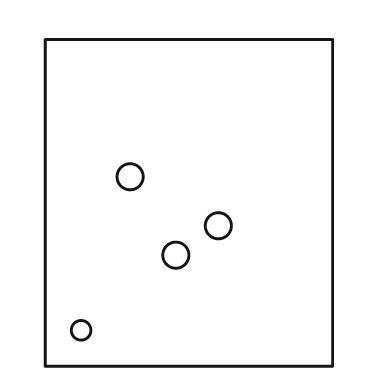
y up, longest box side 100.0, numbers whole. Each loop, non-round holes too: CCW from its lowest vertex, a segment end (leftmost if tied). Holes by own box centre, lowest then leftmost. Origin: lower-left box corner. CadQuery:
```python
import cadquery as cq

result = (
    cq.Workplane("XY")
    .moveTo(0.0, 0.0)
    .lineTo(88.0, 0.0)
    .lineTo(88.0, 100.0)
    .lineTo(0.0, 100.0)
    .close()
    .moveTo(11.0, 11.0)
    .circle(3.0)
    .moveTo(40.0, 34.0)
    .circle(4.0)
    .moveTo(53.0, 43.0)
    .circle(4.0)
    .moveTo(26.0, 58.0)
    .circle(4.0)
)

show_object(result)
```